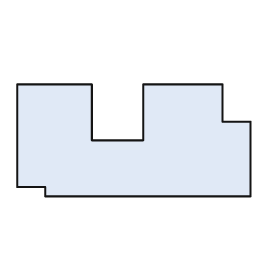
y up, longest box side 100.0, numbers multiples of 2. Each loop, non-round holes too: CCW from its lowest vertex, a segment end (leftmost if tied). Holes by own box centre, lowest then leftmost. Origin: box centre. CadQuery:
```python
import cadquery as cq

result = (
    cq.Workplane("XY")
    .moveTo(-38.0, -24.0)
    .lineTo(50.0, -24.0)
    .lineTo(50.0, 8.0)
    .lineTo(38.0, 8.0)
    .lineTo(38.0, 24.0)
    .lineTo(4.0, 24.0)
    .lineTo(4.0, 0.0)
    .lineTo(-18.0, 0.0)
    .lineTo(-18.0, 24.0)
    .lineTo(-50.0, 24.0)
    .lineTo(-50.0, -20.0)
    .lineTo(-38.0, -20.0)
    .close()
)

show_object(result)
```